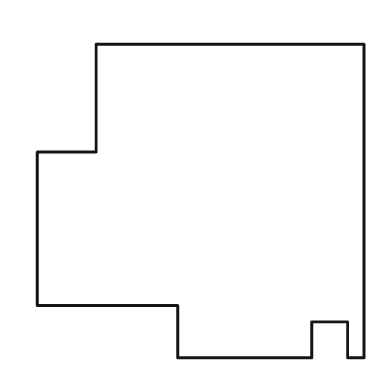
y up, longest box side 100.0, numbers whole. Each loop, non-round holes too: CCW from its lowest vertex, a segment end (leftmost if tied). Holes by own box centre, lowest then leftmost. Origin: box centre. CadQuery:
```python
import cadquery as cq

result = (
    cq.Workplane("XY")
    .moveTo(-7.0, -48.0)
    .lineTo(34.0, -48.0)
    .lineTo(34.0, -37.0)
    .lineTo(45.0, -37.0)
    .lineTo(45.0, -48.0)
    .lineTo(50.0, -48.0)
    .lineTo(50.0, 48.0)
    .lineTo(-32.0, 48.0)
    .lineTo(-32.0, 15.0)
    .lineTo(-50.0, 15.0)
    .lineTo(-50.0, -32.0)
    .lineTo(-7.0, -32.0)
    .close()
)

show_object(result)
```